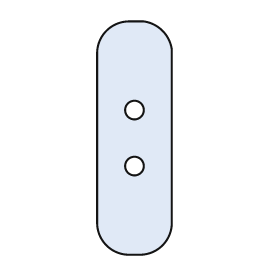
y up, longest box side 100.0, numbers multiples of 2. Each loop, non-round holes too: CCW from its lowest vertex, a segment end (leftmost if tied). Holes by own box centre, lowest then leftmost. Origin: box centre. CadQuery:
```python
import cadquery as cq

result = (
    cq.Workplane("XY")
    .moveTo(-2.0, -50.0)
    .lineTo(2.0, -50.0)
    .threePointArc((12.0, -46.0), (16.0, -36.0))
    .lineTo(16.0, 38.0)
    .threePointArc((12.0, 46.0), (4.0, 50.0))
    .lineTo(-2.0, 50.0)
    .threePointArc((-12.0, 46.0), (-16.0, 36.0))
    .lineTo(-16.0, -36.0)
    .threePointArc((-12.0, -46.0), (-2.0, -50.0))
    .close()
    .moveTo(0.0, -12.0)
    .circle(4.0)
    .moveTo(0.0, 12.0)
    .circle(4.0)
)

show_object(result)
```